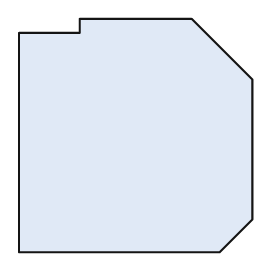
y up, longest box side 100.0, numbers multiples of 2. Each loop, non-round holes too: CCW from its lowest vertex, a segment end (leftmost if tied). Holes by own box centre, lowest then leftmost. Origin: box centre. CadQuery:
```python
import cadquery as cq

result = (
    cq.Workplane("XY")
    .moveTo(-50.0, -50.0)
    .lineTo(36.0, -50.0)
    .lineTo(50.0, -36.0)
    .lineTo(50.0, 24.0)
    .lineTo(24.0, 50.0)
    .lineTo(-24.0, 50.0)
    .lineTo(-24.0, 44.0)
    .lineTo(-50.0, 44.0)
    .close()
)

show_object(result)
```